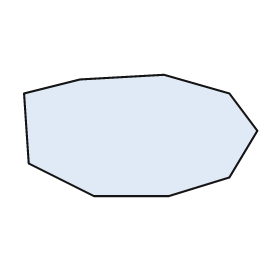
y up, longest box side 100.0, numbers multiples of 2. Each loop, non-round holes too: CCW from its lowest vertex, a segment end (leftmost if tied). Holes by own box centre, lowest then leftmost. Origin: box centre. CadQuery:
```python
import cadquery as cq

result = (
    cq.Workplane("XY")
    .moveTo(-20.0, -26.0)
    .lineTo(12.0, -26.0)
    .lineTo(38.0, -18.0)
    .lineTo(50.0, 2.0)
    .lineTo(38.0, 18.0)
    .lineTo(10.0, 26.0)
    .lineTo(-26.0, 24.0)
    .lineTo(-50.0, 18.0)
    .lineTo(-48.0, -12.0)
    .close()
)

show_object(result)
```